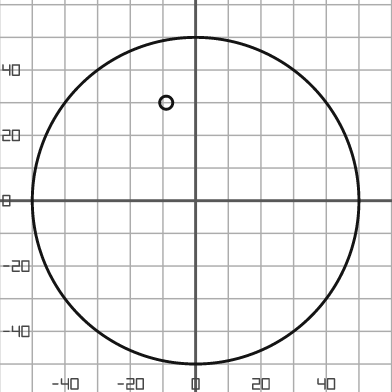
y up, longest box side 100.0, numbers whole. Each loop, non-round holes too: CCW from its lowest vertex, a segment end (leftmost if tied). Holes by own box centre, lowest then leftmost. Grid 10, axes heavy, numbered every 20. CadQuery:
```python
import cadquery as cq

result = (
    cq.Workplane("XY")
    .moveTo(0.0, 0.0)
    .circle(50.0)
    .moveTo(-9.0, 30.0)
    .circle(2.0)
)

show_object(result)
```